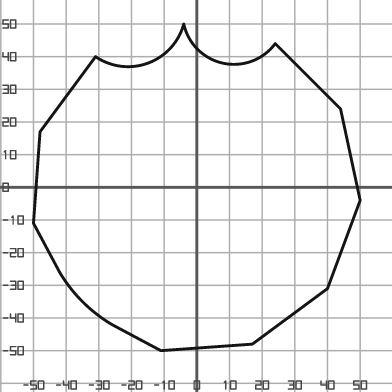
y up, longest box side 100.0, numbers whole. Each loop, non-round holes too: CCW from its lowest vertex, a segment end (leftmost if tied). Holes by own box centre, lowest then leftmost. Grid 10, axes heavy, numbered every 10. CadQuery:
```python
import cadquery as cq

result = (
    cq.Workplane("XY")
    .moveTo(-11.0, -50.0)
    .lineTo(17.0, -48.0)
    .lineTo(40.0, -31.0)
    .lineTo(50.0, -4.0)
    .lineTo(44.0, 24.0)
    .lineTo(24.0, 44.0)
    .threePointArc((8.0, 38.0), (-4.0, 50.0))
    .threePointArc((-15.0, 38.0), (-31.0, 40.0))
    .lineTo(-48.0, 17.0)
    .lineTo(-50.0, -11.0)
    .lineTo(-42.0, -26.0)
    .threePointArc((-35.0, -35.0), (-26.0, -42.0))
    .close()
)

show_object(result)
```